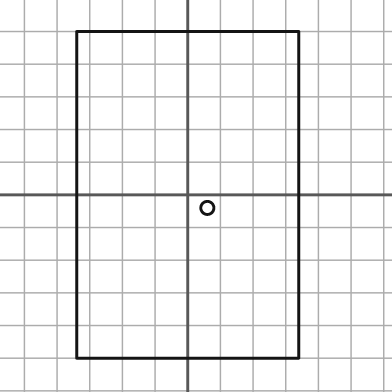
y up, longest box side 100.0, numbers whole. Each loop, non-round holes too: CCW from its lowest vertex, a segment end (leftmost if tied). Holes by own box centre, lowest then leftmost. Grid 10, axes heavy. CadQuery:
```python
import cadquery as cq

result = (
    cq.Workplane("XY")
    .moveTo(-34.0, -50.0)
    .lineTo(34.0, -50.0)
    .lineTo(34.0, 50.0)
    .lineTo(-34.0, 50.0)
    .close()
    .moveTo(6.0, -4.0)
    .circle(2.0)
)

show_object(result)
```